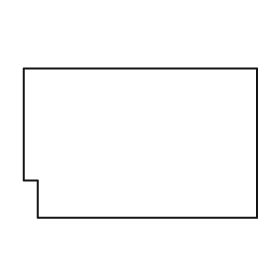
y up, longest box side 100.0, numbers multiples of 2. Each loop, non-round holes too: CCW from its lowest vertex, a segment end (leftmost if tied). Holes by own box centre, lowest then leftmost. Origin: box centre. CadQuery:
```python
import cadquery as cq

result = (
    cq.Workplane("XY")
    .moveTo(-44.0, -32.0)
    .lineTo(50.0, -32.0)
    .lineTo(50.0, 32.0)
    .lineTo(-50.0, 32.0)
    .lineTo(-50.0, -16.0)
    .lineTo(-44.0, -16.0)
    .close()
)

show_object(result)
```